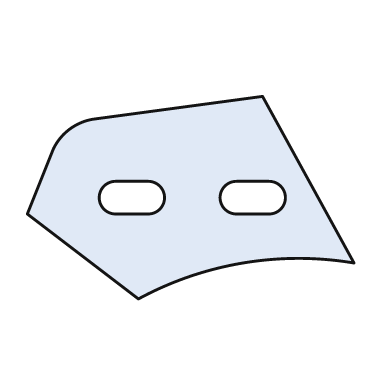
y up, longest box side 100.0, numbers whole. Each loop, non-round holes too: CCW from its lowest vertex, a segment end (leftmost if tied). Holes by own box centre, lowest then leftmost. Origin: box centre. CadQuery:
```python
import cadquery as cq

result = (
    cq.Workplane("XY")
    .moveTo(-16.0, -31.0)
    .threePointArc((16.0, -20.0), (50.0, -20.0))
    .lineTo(22.0, 31.0)
    .lineTo(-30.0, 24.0)
    .threePointArc((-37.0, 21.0), (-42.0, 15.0))
    .lineTo(-50.0, -5.0)
    .close()
    .moveTo(-23.0, -5.0)
    .lineTo(-13.0, -5.0)
    .threePointArc((-8.0, 0.0), (-13.0, 5.0))
    .lineTo(-23.0, 5.0)
    .threePointArc((-28.0, 0.0), (-23.0, -5.0))
    .close()
    .moveTo(14.0, -5.0)
    .lineTo(24.0, -5.0)
    .threePointArc((29.0, 0.0), (24.0, 5.0))
    .lineTo(14.0, 5.0)
    .threePointArc((9.0, 0.0), (14.0, -5.0))
    .close()
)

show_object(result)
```